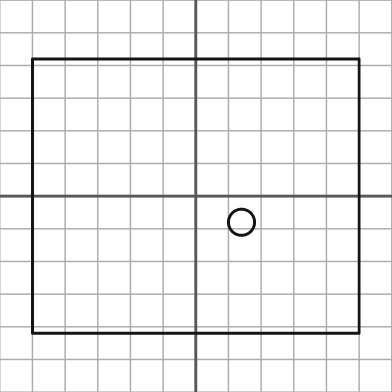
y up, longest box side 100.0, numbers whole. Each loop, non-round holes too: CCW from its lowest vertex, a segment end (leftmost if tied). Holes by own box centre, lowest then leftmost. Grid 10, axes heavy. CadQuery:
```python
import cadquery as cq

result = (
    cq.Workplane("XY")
    .moveTo(-50.0, -42.0)
    .lineTo(50.0, -42.0)
    .lineTo(50.0, 42.0)
    .lineTo(-50.0, 42.0)
    .close()
    .moveTo(14.0, -8.0)
    .circle(4.0)
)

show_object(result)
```